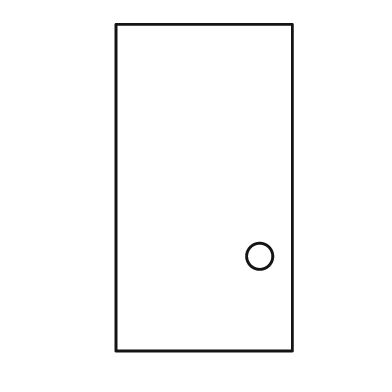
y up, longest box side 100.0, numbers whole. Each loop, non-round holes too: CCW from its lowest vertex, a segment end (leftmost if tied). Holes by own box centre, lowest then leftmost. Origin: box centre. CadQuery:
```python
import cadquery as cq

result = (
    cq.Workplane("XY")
    .moveTo(-27.0, -50.0)
    .lineTo(27.0, -50.0)
    .lineTo(27.0, 50.0)
    .lineTo(-27.0, 50.0)
    .close()
    .moveTo(17.0, -21.0)
    .circle(4.0)
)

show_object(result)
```